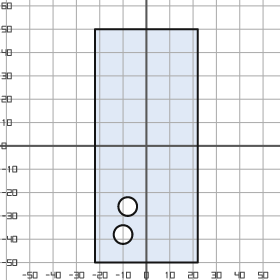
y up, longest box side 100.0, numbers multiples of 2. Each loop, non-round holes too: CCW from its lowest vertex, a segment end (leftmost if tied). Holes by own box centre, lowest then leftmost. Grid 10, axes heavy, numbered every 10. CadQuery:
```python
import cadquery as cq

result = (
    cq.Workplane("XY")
    .moveTo(-22.0, -50.0)
    .lineTo(22.0, -50.0)
    .lineTo(22.0, 50.0)
    .lineTo(-22.0, 50.0)
    .close()
    .moveTo(-10.0, -38.0)
    .circle(4.0)
    .moveTo(-8.0, -26.0)
    .circle(4.0)
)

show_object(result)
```